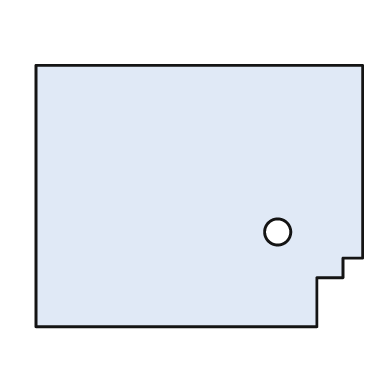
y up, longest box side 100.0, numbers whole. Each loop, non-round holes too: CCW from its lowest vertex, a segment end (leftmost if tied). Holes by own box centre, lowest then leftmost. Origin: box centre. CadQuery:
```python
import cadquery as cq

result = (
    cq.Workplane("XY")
    .moveTo(-50.0, -40.0)
    .lineTo(36.0, -40.0)
    .lineTo(36.0, -25.0)
    .lineTo(44.0, -25.0)
    .lineTo(44.0, -19.0)
    .lineTo(50.0, -19.0)
    .lineTo(50.0, 40.0)
    .lineTo(-50.0, 40.0)
    .close()
    .moveTo(24.0, -11.0)
    .circle(4.0)
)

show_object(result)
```